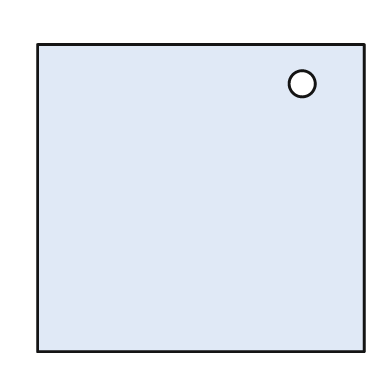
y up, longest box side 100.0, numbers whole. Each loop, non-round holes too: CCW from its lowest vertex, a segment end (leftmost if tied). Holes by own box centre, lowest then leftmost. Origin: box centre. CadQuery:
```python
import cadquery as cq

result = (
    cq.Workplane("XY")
    .moveTo(-50.0, -47.0)
    .lineTo(50.0, -47.0)
    .lineTo(50.0, 47.0)
    .lineTo(-50.0, 47.0)
    .close()
    .moveTo(31.0, 35.0)
    .circle(4.0)
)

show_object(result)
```